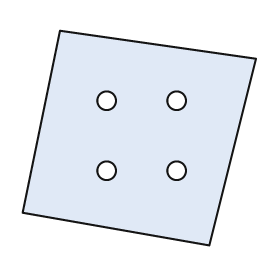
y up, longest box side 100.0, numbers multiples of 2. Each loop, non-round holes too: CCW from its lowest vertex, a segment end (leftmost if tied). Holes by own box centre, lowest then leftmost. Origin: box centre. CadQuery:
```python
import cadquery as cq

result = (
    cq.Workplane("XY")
    .moveTo(30.0, -46.0)
    .lineTo(50.0, 34.0)
    .lineTo(-34.0, 46.0)
    .lineTo(-50.0, -32.0)
    .close()
    .moveTo(-14.0, -14.0)
    .circle(4.0)
    .moveTo(16.0, -14.0)
    .circle(4.0)
    .moveTo(-14.0, 16.0)
    .circle(4.0)
    .moveTo(16.0, 16.0)
    .circle(4.0)
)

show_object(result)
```